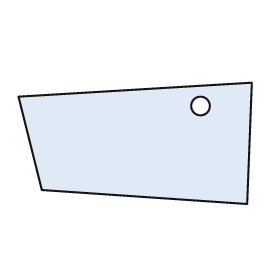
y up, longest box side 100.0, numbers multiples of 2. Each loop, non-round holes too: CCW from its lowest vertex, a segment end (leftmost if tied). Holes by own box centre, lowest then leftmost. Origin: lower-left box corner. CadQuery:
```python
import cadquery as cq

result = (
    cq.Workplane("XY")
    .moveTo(98.0, 0.0)
    .lineTo(100.0, 52.0)
    .lineTo(0.0, 46.0)
    .lineTo(10.0, 6.0)
    .close()
    .moveTo(78.0, 42.0)
    .circle(4.0)
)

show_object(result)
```